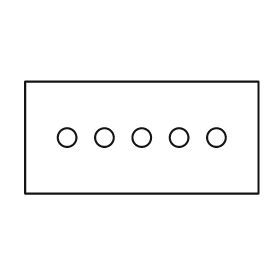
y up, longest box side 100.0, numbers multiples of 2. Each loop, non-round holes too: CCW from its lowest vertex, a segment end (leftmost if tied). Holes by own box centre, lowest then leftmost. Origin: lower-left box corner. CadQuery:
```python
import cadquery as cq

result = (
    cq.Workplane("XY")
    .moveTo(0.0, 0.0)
    .lineTo(100.0, 0.0)
    .lineTo(100.0, 48.0)
    .lineTo(0.0, 48.0)
    .close()
    .moveTo(18.0, 24.0)
    .circle(4.0)
    .moveTo(34.0, 24.0)
    .circle(4.0)
    .moveTo(50.0, 24.0)
    .circle(4.0)
    .moveTo(66.0, 24.0)
    .circle(4.0)
    .moveTo(82.0, 24.0)
    .circle(4.0)
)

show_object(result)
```